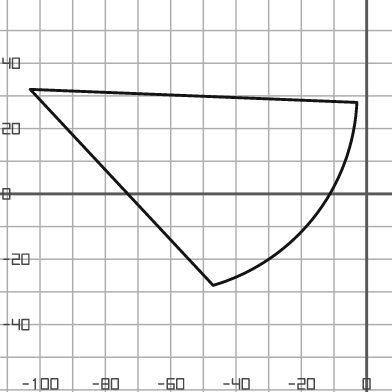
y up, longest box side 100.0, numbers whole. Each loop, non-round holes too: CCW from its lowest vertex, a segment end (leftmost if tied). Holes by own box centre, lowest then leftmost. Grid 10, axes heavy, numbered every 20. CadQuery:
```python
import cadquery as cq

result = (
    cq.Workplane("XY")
    .moveTo(-47.0, -28.0)
    .threePointArc((-16.0, -7.0), (-3.0, 28.0))
    .lineTo(-103.0, 32.0)
    .close()
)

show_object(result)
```